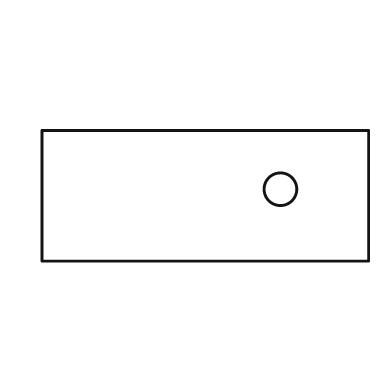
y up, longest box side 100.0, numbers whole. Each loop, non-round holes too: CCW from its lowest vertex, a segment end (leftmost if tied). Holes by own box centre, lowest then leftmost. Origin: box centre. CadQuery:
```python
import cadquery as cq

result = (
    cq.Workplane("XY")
    .moveTo(-50.0, -20.0)
    .lineTo(50.0, -20.0)
    .lineTo(50.0, 20.0)
    .lineTo(-50.0, 20.0)
    .close()
    .moveTo(23.0, 2.0)
    .circle(5.0)
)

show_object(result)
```